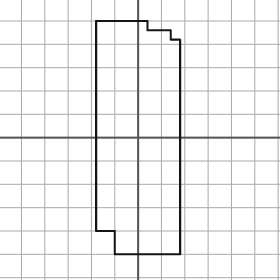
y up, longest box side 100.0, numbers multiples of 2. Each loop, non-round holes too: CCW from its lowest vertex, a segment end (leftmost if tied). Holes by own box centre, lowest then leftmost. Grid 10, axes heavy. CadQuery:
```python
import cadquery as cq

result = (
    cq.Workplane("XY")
    .moveTo(-10.0, -50.0)
    .lineTo(18.0, -50.0)
    .lineTo(18.0, 42.0)
    .lineTo(14.0, 42.0)
    .lineTo(14.0, 46.0)
    .lineTo(4.0, 46.0)
    .lineTo(4.0, 50.0)
    .lineTo(-18.0, 50.0)
    .lineTo(-18.0, -40.0)
    .lineTo(-10.0, -40.0)
    .close()
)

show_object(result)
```